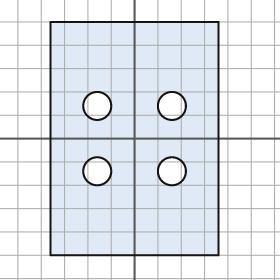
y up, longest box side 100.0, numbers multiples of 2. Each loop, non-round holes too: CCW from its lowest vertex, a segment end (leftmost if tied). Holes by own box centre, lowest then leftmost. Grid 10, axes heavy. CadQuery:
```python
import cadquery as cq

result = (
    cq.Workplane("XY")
    .moveTo(-36.0, -50.0)
    .lineTo(36.0, -50.0)
    .lineTo(36.0, 50.0)
    .lineTo(-36.0, 50.0)
    .close()
    .moveTo(-16.0, -14.0)
    .circle(6.0)
    .moveTo(16.0, -14.0)
    .circle(6.0)
    .moveTo(-16.0, 14.0)
    .circle(6.0)
    .moveTo(16.0, 14.0)
    .circle(6.0)
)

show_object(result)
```